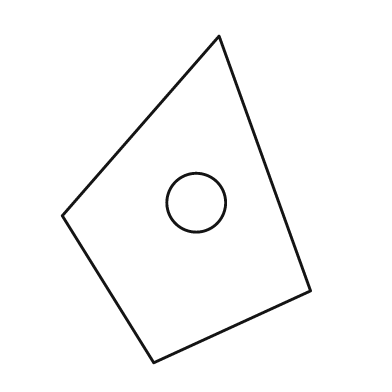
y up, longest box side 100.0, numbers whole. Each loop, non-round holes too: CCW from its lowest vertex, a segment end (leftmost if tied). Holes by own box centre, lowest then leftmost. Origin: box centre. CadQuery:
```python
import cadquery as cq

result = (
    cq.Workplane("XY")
    .moveTo(-10.0, -50.0)
    .lineTo(38.0, -28.0)
    .lineTo(10.0, 50.0)
    .lineTo(-38.0, -5.0)
    .close()
    .moveTo(3.0, -1.0)
    .circle(9.0)
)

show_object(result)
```